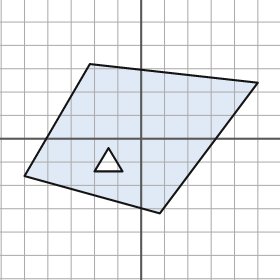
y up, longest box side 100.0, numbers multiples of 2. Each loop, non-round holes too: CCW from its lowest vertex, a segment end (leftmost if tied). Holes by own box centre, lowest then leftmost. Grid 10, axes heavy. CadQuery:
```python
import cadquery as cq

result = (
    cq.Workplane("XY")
    .moveTo(8.0, -32.0)
    .lineTo(50.0, 24.0)
    .lineTo(-22.0, 32.0)
    .lineTo(-50.0, -16.0)
    .close()
    .moveTo(-20.0, -14.0)
    .lineTo(-8.0, -14.0)
    .lineTo(-14.0, -4.0)
    .close()
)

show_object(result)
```